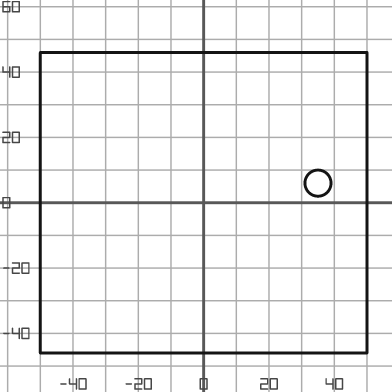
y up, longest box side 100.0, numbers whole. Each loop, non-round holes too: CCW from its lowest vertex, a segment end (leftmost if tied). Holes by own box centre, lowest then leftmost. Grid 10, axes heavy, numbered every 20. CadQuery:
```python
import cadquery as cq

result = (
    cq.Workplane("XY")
    .moveTo(-50.0, -46.0)
    .lineTo(50.0, -46.0)
    .lineTo(50.0, 46.0)
    .lineTo(-50.0, 46.0)
    .close()
    .moveTo(35.0, 6.0)
    .circle(4.0)
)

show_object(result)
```